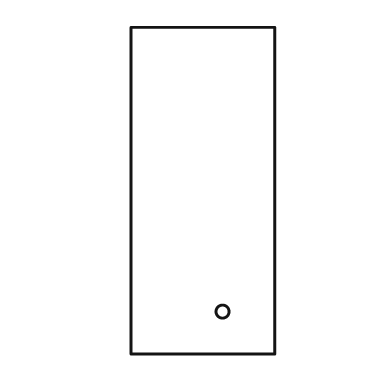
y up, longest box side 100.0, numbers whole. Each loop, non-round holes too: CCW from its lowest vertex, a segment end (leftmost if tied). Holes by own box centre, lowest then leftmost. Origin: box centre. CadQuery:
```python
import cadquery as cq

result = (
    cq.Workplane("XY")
    .moveTo(-22.0, -50.0)
    .lineTo(22.0, -50.0)
    .lineTo(22.0, 50.0)
    .lineTo(-22.0, 50.0)
    .close()
    .moveTo(6.0, -37.0)
    .circle(2.0)
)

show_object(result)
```